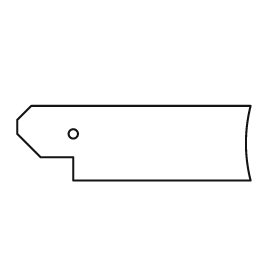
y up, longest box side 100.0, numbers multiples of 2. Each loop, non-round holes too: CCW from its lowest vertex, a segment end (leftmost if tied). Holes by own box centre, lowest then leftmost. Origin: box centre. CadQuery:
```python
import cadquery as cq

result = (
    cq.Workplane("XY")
    .moveTo(-26.0, -16.0)
    .lineTo(50.0, -16.0)
    .threePointArc((48.0, 0.0), (50.0, 16.0))
    .lineTo(-44.0, 16.0)
    .lineTo(-50.0, 10.0)
    .lineTo(-50.0, 4.0)
    .lineTo(-40.0, -6.0)
    .lineTo(-26.0, -6.0)
    .close()
    .moveTo(-26.0, 4.0)
    .circle(2.0)
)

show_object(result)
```